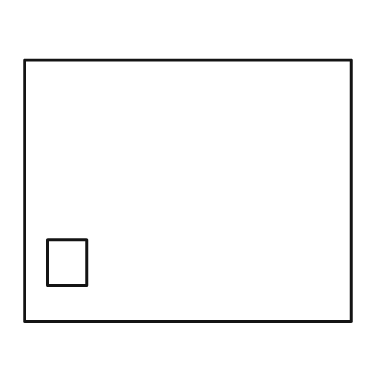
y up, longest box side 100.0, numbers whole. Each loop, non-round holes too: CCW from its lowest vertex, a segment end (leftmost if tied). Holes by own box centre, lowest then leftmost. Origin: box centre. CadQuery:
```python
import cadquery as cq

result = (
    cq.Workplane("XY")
    .moveTo(-50.0, -40.0)
    .lineTo(50.0, -40.0)
    .lineTo(50.0, 40.0)
    .lineTo(-50.0, 40.0)
    .close()
    .moveTo(-43.0, -29.0)
    .lineTo(-31.0, -29.0)
    .lineTo(-31.0, -15.0)
    .lineTo(-43.0, -15.0)
    .close()
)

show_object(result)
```